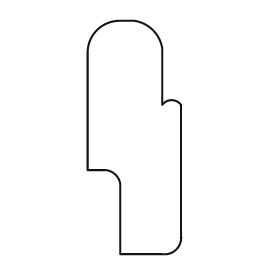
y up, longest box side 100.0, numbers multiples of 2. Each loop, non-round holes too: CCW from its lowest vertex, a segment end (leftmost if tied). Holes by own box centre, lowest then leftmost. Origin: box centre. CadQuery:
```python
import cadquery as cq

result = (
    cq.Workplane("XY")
    .moveTo(-6.0, -50.0)
    .lineTo(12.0, -50.0)
    .threePointArc((18.0, -48.0), (20.0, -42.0))
    .lineTo(20.0, 14.0)
    .threePointArc((16.0, 16.0), (12.0, 14.0))
    .lineTo(12.0, 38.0)
    .threePointArc((8.0, 46.0), (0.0, 50.0))
    .lineTo(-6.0, 50.0)
    .threePointArc((-16.0, 46.0), (-20.0, 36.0))
    .lineTo(-20.0, -14.0)
    .lineTo(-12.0, -14.0)
    .threePointArc((-8.0, -16.0), (-6.0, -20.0))
    .close()
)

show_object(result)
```